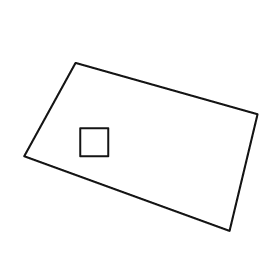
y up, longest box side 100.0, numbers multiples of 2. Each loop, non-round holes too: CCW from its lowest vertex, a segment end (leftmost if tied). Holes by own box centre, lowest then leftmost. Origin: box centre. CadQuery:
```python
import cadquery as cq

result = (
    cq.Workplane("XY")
    .moveTo(38.0, -36.0)
    .lineTo(50.0, 14.0)
    .lineTo(-28.0, 36.0)
    .lineTo(-50.0, -4.0)
    .close()
    .moveTo(-26.0, -4.0)
    .lineTo(-14.0, -4.0)
    .lineTo(-14.0, 8.0)
    .lineTo(-26.0, 8.0)
    .close()
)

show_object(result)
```